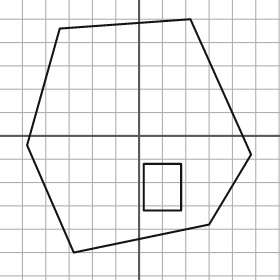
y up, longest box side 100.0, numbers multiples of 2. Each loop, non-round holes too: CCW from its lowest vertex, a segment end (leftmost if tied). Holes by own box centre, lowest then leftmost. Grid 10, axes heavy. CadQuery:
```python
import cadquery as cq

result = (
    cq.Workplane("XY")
    .moveTo(-28.0, -50.0)
    .lineTo(30.0, -38.0)
    .lineTo(48.0, -8.0)
    .lineTo(22.0, 50.0)
    .lineTo(-34.0, 46.0)
    .lineTo(-48.0, -4.0)
    .close()
    .moveTo(2.0, -32.0)
    .lineTo(18.0, -32.0)
    .lineTo(18.0, -12.0)
    .lineTo(2.0, -12.0)
    .close()
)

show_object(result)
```